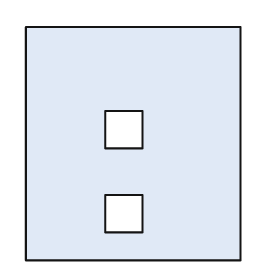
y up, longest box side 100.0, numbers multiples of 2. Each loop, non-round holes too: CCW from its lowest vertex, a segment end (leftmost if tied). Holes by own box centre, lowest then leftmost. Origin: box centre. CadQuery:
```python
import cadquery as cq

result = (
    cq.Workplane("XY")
    .moveTo(-46.0, -50.0)
    .lineTo(46.0, -50.0)
    .lineTo(46.0, 50.0)
    .lineTo(-46.0, 50.0)
    .close()
    .moveTo(-12.0, -38.0)
    .lineTo(4.0, -38.0)
    .lineTo(4.0, -22.0)
    .lineTo(-12.0, -22.0)
    .close()
    .moveTo(-12.0, -2.0)
    .lineTo(4.0, -2.0)
    .lineTo(4.0, 14.0)
    .lineTo(-12.0, 14.0)
    .close()
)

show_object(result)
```